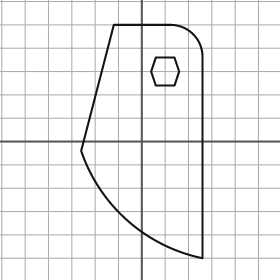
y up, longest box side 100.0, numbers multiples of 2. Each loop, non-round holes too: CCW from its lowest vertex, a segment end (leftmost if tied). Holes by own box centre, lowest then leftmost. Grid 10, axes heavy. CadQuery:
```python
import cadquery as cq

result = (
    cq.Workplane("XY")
    .moveTo(26.0, -50.0)
    .lineTo(26.0, 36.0)
    .threePointArc((22.0, 46.0), (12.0, 50.0))
    .lineTo(-12.0, 50.0)
    .lineTo(-26.0, -4.0)
    .threePointArc((-6.0, -34.0), (26.0, -50.0))
    .close()
    .moveTo(6.0, 24.0)
    .lineTo(14.0, 24.0)
    .lineTo(16.0, 30.0)
    .lineTo(14.0, 36.0)
    .lineTo(6.0, 36.0)
    .lineTo(4.0, 30.0)
    .close()
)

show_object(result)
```